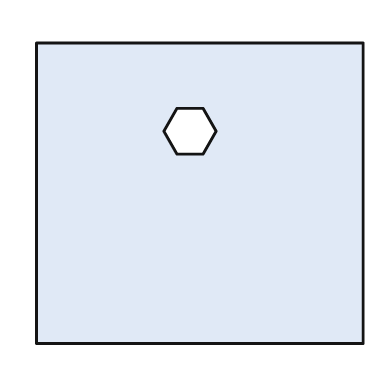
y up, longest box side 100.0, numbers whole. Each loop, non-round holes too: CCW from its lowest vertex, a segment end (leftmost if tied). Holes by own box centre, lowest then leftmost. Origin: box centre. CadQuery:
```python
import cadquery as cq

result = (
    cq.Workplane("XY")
    .moveTo(-50.0, -46.0)
    .lineTo(50.0, -46.0)
    .lineTo(50.0, 46.0)
    .lineTo(-50.0, 46.0)
    .close()
    .moveTo(-7.0, 12.0)
    .lineTo(1.0, 12.0)
    .lineTo(5.0, 19.0)
    .lineTo(1.0, 26.0)
    .lineTo(-7.0, 26.0)
    .lineTo(-11.0, 19.0)
    .close()
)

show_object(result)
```